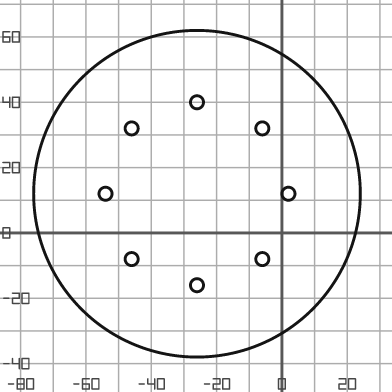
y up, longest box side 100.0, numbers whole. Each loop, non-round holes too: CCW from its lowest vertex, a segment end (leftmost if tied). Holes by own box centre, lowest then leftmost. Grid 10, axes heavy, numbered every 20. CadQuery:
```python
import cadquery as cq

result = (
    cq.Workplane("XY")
    .moveTo(-26.0, 12.0)
    .circle(50.0)
    .moveTo(-26.0, -16.0)
    .circle(2.0)
    .moveTo(-46.0, -8.0)
    .circle(2.0)
    .moveTo(-6.0, -8.0)
    .circle(2.0)
    .moveTo(-54.0, 12.0)
    .circle(2.0)
    .moveTo(2.0, 12.0)
    .circle(2.0)
    .moveTo(-46.0, 32.0)
    .circle(2.0)
    .moveTo(-6.0, 32.0)
    .circle(2.0)
    .moveTo(-26.0, 40.0)
    .circle(2.0)
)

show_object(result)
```